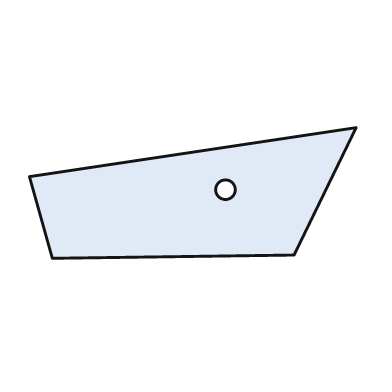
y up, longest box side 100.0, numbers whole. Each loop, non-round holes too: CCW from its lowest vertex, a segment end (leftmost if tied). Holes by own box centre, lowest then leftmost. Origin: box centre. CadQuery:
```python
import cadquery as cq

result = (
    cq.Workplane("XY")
    .moveTo(-43.0, -20.0)
    .lineTo(31.0, -19.0)
    .lineTo(50.0, 20.0)
    .lineTo(-50.0, 5.0)
    .close()
    .moveTo(10.0, 1.0)
    .circle(3.0)
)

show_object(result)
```